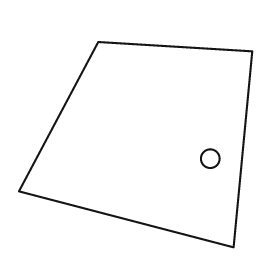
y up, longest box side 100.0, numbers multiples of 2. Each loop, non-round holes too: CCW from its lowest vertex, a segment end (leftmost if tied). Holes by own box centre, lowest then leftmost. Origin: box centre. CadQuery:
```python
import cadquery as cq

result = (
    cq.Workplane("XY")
    .moveTo(42.0, -44.0)
    .lineTo(50.0, 40.0)
    .lineTo(-16.0, 44.0)
    .lineTo(-50.0, -20.0)
    .close()
    .moveTo(32.0, -6.0)
    .circle(4.0)
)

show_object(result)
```